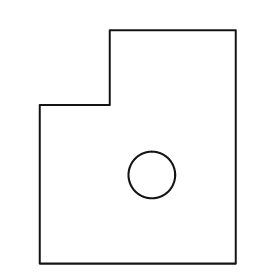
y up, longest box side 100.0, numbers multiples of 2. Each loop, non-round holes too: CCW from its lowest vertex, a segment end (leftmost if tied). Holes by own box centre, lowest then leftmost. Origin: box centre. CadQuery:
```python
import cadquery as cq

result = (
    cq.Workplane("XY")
    .moveTo(-42.0, -50.0)
    .lineTo(42.0, -50.0)
    .lineTo(42.0, 50.0)
    .lineTo(-12.0, 50.0)
    .lineTo(-12.0, 18.0)
    .lineTo(-42.0, 18.0)
    .close()
    .moveTo(6.0, -12.0)
    .circle(10.0)
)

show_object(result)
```